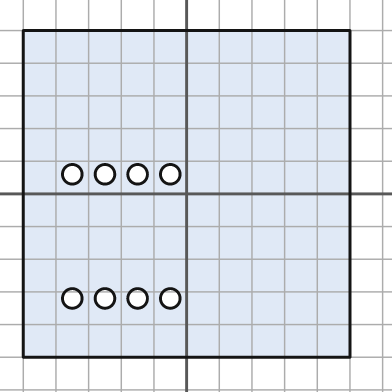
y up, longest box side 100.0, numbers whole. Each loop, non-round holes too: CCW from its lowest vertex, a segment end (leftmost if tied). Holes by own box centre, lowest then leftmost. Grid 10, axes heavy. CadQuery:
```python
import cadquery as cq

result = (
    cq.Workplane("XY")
    .moveTo(-50.0, -50.0)
    .lineTo(50.0, -50.0)
    .lineTo(50.0, 50.0)
    .lineTo(-50.0, 50.0)
    .close()
    .moveTo(-35.0, -32.0)
    .circle(3.0)
    .moveTo(-25.0, -32.0)
    .circle(3.0)
    .moveTo(-15.0, -32.0)
    .circle(3.0)
    .moveTo(-5.0, -32.0)
    .circle(3.0)
    .moveTo(-35.0, 6.0)
    .circle(3.0)
    .moveTo(-25.0, 6.0)
    .circle(3.0)
    .moveTo(-15.0, 6.0)
    .circle(3.0)
    .moveTo(-5.0, 6.0)
    .circle(3.0)
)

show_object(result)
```